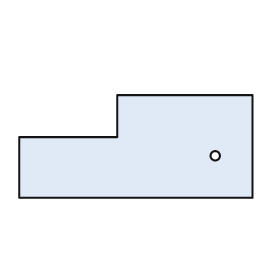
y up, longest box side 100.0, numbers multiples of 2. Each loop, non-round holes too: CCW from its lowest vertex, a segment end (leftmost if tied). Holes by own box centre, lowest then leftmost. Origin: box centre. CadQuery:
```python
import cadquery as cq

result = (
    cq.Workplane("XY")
    .moveTo(-50.0, -22.0)
    .lineTo(50.0, -22.0)
    .lineTo(50.0, 22.0)
    .lineTo(-8.0, 22.0)
    .lineTo(-8.0, 4.0)
    .lineTo(-50.0, 4.0)
    .close()
    .moveTo(34.0, -4.0)
    .circle(2.0)
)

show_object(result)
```